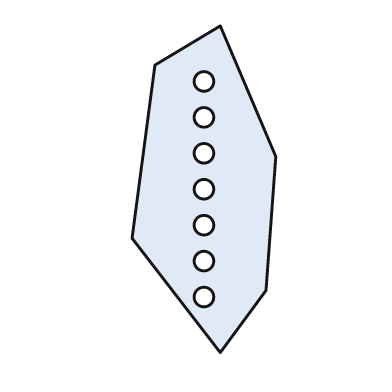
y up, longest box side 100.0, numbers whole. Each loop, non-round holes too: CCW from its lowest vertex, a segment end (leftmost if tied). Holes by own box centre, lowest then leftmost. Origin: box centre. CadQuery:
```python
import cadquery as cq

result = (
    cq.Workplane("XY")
    .moveTo(5.0, -50.0)
    .lineTo(19.0, -31.0)
    .lineTo(22.0, 10.0)
    .lineTo(5.0, 50.0)
    .lineTo(-15.0, 38.0)
    .lineTo(-22.0, -15.0)
    .close()
    .moveTo(0.0, -33.0)
    .circle(3.0)
    .moveTo(0.0, -22.0)
    .circle(3.0)
    .moveTo(0.0, -11.0)
    .circle(3.0)
    .moveTo(0.0, 0.0)
    .circle(3.0)
    .moveTo(0.0, 11.0)
    .circle(3.0)
    .moveTo(0.0, 22.0)
    .circle(3.0)
    .moveTo(0.0, 33.0)
    .circle(3.0)
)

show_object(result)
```